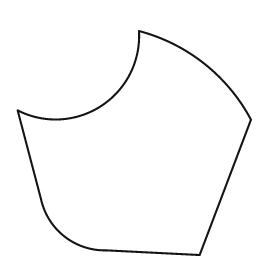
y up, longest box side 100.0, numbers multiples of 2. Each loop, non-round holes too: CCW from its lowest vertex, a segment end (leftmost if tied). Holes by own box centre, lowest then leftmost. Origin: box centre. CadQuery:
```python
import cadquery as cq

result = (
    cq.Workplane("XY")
    .moveTo(28.0, -48.0)
    .lineTo(50.0, 10.0)
    .threePointArc((30.0, 34.0), (2.0, 48.0))
    .threePointArc((-14.0, 16.0), (-50.0, 14.0))
    .lineTo(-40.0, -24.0)
    .threePointArc((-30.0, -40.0), (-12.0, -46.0))
    .close()
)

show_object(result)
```